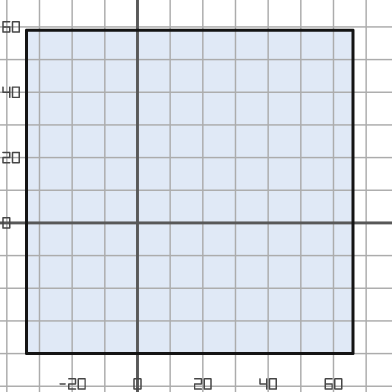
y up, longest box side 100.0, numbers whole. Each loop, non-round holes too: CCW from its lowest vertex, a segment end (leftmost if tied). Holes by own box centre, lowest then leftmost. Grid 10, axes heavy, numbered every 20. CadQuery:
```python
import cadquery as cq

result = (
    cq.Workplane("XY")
    .moveTo(-34.0, -40.0)
    .lineTo(66.0, -40.0)
    .lineTo(66.0, 59.0)
    .lineTo(-34.0, 59.0)
    .close()
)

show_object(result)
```